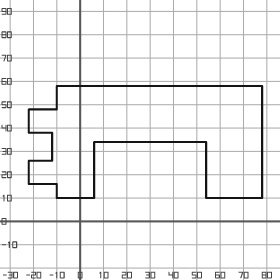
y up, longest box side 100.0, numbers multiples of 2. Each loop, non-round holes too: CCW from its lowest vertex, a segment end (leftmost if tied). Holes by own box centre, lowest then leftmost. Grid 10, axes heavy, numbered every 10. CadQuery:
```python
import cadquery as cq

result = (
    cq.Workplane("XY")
    .moveTo(-10.0, 10.0)
    .lineTo(6.0, 10.0)
    .lineTo(6.0, 34.0)
    .lineTo(54.0, 34.0)
    .lineTo(54.0, 10.0)
    .lineTo(78.0, 10.0)
    .lineTo(78.0, 58.0)
    .lineTo(-10.0, 58.0)
    .lineTo(-10.0, 48.0)
    .lineTo(-22.0, 48.0)
    .lineTo(-22.0, 38.0)
    .lineTo(-12.0, 38.0)
    .lineTo(-12.0, 26.0)
    .lineTo(-22.0, 26.0)
    .lineTo(-22.0, 16.0)
    .lineTo(-10.0, 16.0)
    .close()
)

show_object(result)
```